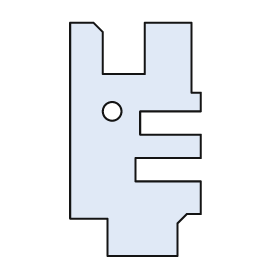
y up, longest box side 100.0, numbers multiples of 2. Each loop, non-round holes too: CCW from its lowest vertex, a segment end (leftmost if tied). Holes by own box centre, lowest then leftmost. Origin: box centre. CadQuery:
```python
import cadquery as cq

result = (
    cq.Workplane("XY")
    .moveTo(-12.0, -50.0)
    .lineTo(18.0, -50.0)
    .lineTo(18.0, -36.0)
    .lineTo(22.0, -32.0)
    .lineTo(28.0, -32.0)
    .lineTo(28.0, -18.0)
    .lineTo(0.0, -18.0)
    .lineTo(0.0, -8.0)
    .lineTo(28.0, -8.0)
    .lineTo(28.0, 2.0)
    .lineTo(2.0, 2.0)
    .lineTo(2.0, 12.0)
    .lineTo(28.0, 12.0)
    .lineTo(28.0, 20.0)
    .lineTo(24.0, 20.0)
    .lineTo(24.0, 50.0)
    .lineTo(4.0, 50.0)
    .lineTo(4.0, 28.0)
    .lineTo(-14.0, 28.0)
    .lineTo(-14.0, 46.0)
    .lineTo(-18.0, 50.0)
    .lineTo(-28.0, 50.0)
    .lineTo(-28.0, -34.0)
    .lineTo(-12.0, -34.0)
    .close()
    .moveTo(-10.0, 12.0)
    .circle(4.0)
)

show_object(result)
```